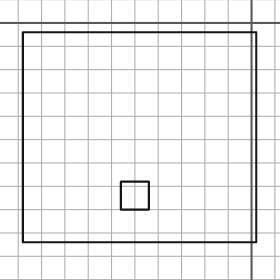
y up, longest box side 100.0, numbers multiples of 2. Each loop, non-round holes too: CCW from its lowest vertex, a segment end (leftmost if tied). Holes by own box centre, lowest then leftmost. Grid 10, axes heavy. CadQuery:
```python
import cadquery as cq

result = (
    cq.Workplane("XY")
    .moveTo(-98.0, -94.0)
    .lineTo(2.0, -94.0)
    .lineTo(2.0, -4.0)
    .lineTo(-98.0, -4.0)
    .close()
    .moveTo(-56.0, -80.0)
    .lineTo(-44.0, -80.0)
    .lineTo(-44.0, -68.0)
    .lineTo(-56.0, -68.0)
    .close()
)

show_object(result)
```